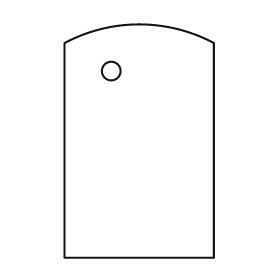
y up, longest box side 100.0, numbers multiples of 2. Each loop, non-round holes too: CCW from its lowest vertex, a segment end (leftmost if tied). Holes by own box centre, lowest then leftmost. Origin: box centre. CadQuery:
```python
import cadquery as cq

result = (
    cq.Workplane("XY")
    .moveTo(-32.0, -50.0)
    .lineTo(32.0, -50.0)
    .lineTo(32.0, 42.0)
    .threePointArc((0.0, 50.0), (-32.0, 42.0))
    .close()
    .moveTo(-12.0, 30.0)
    .circle(4.0)
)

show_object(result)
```